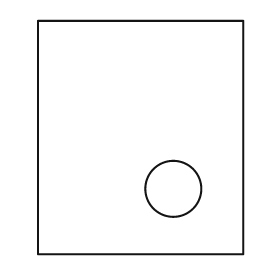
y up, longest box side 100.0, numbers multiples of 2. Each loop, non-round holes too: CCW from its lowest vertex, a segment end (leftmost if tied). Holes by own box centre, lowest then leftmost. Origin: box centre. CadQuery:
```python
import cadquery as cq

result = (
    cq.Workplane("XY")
    .moveTo(-44.0, -50.0)
    .lineTo(44.0, -50.0)
    .lineTo(44.0, 50.0)
    .lineTo(-44.0, 50.0)
    .close()
    .moveTo(14.0, -22.0)
    .circle(12.0)
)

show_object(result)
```